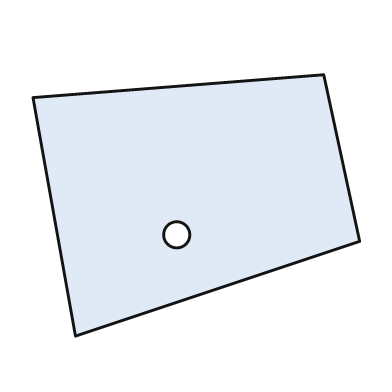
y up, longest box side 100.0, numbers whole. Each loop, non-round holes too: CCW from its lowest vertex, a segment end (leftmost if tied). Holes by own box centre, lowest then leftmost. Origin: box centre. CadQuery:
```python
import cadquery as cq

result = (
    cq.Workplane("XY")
    .moveTo(-37.0, -40.0)
    .lineTo(50.0, -11.0)
    .lineTo(39.0, 40.0)
    .lineTo(-50.0, 33.0)
    .close()
    .moveTo(-6.0, -9.0)
    .circle(4.0)
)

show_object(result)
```